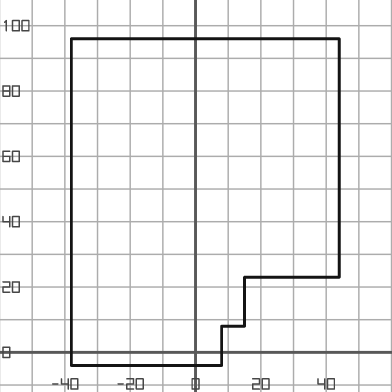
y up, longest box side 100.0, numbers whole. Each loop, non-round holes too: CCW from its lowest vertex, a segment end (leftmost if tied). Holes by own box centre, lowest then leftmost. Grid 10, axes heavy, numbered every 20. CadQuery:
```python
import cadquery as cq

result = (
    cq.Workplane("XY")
    .moveTo(-38.0, -4.0)
    .lineTo(8.0, -4.0)
    .lineTo(8.0, 8.0)
    .lineTo(15.0, 8.0)
    .lineTo(15.0, 23.0)
    .lineTo(44.0, 23.0)
    .lineTo(44.0, 96.0)
    .lineTo(-38.0, 96.0)
    .close()
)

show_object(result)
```